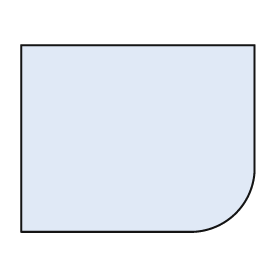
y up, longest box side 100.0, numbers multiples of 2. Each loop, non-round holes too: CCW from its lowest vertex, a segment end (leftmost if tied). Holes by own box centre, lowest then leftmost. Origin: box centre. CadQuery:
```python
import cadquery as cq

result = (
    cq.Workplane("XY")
    .moveTo(-50.0, -40.0)
    .lineTo(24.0, -40.0)
    .threePointArc((42.0, -32.0), (50.0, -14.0))
    .lineTo(50.0, 40.0)
    .lineTo(-50.0, 40.0)
    .close()
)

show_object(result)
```